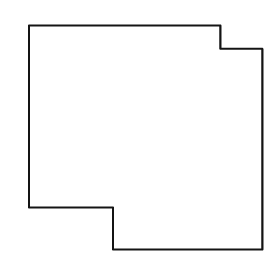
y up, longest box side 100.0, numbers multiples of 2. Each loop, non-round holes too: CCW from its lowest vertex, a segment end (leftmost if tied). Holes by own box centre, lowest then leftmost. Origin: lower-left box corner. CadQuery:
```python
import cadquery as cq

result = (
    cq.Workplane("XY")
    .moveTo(36.0, 0.0)
    .lineTo(100.0, 0.0)
    .lineTo(100.0, 86.0)
    .lineTo(82.0, 86.0)
    .lineTo(82.0, 96.0)
    .lineTo(0.0, 96.0)
    .lineTo(0.0, 18.0)
    .lineTo(36.0, 18.0)
    .close()
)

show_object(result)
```